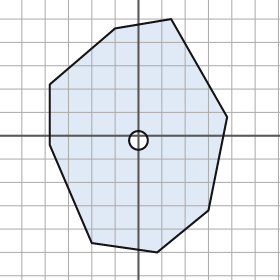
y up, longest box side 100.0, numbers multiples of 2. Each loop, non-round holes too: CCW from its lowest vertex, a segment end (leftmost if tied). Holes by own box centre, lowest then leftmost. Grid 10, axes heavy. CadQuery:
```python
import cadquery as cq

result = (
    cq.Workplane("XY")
    .moveTo(8.0, -50.0)
    .lineTo(30.0, -32.0)
    .lineTo(38.0, 8.0)
    .lineTo(14.0, 50.0)
    .lineTo(-10.0, 46.0)
    .lineTo(-38.0, 22.0)
    .lineTo(-38.0, -4.0)
    .lineTo(-20.0, -46.0)
    .close()
    .moveTo(0.0, -2.0)
    .circle(4.0)
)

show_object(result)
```